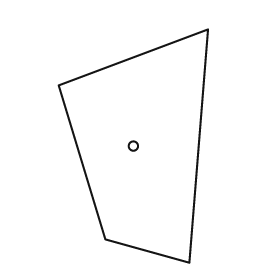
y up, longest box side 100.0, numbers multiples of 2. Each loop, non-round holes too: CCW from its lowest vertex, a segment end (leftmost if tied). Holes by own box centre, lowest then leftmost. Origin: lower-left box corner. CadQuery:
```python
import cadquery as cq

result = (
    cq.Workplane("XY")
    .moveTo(56.0, 0.0)
    .lineTo(64.0, 100.0)
    .lineTo(0.0, 76.0)
    .lineTo(20.0, 10.0)
    .close()
    .moveTo(32.0, 50.0)
    .circle(2.0)
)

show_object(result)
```